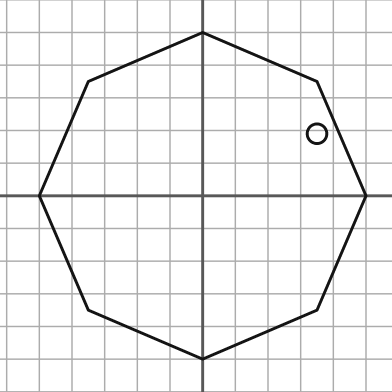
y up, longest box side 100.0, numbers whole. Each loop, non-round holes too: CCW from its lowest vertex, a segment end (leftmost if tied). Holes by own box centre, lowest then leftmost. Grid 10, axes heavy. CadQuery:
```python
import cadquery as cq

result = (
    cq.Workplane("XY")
    .moveTo(0.0, -50.0)
    .lineTo(35.0, -35.0)
    .lineTo(50.0, 0.0)
    .lineTo(35.0, 35.0)
    .lineTo(0.0, 50.0)
    .lineTo(-35.0, 35.0)
    .lineTo(-50.0, 0.0)
    .lineTo(-35.0, -35.0)
    .close()
    .moveTo(35.0, 19.0)
    .circle(3.0)
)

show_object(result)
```